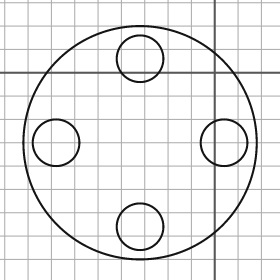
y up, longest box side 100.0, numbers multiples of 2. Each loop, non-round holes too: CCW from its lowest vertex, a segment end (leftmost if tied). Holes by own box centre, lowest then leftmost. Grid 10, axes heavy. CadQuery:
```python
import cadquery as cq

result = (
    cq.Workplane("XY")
    .moveTo(-32.0, -30.0)
    .circle(50.0)
    .moveTo(-32.0, -66.0)
    .circle(10.0)
    .moveTo(-68.0, -30.0)
    .circle(10.0)
    .moveTo(4.0, -30.0)
    .circle(10.0)
    .moveTo(-32.0, 6.0)
    .circle(10.0)
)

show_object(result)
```